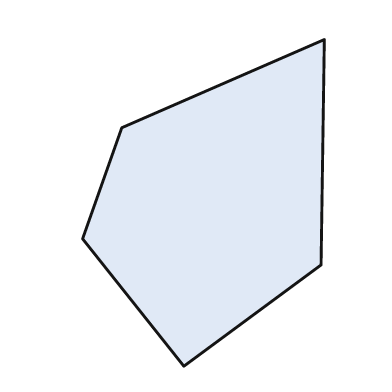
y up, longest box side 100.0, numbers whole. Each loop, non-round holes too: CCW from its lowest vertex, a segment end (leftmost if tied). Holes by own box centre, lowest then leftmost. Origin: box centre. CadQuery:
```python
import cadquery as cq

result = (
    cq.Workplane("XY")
    .moveTo(-6.0, -50.0)
    .lineTo(36.0, -19.0)
    .lineTo(37.0, 50.0)
    .lineTo(-25.0, 23.0)
    .lineTo(-37.0, -11.0)
    .close()
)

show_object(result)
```